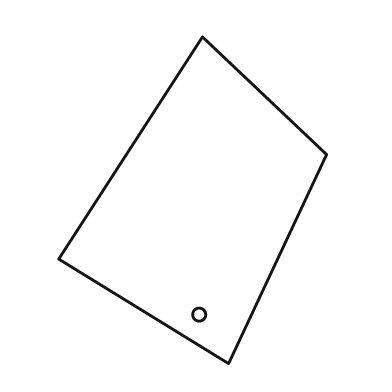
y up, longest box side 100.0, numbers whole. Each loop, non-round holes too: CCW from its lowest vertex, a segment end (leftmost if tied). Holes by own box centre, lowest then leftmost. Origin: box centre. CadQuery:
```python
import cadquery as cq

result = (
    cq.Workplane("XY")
    .moveTo(11.0, -50.0)
    .lineTo(41.0, 14.0)
    .lineTo(3.0, 50.0)
    .lineTo(-41.0, -18.0)
    .close()
    .moveTo(2.0, -35.0)
    .circle(2.0)
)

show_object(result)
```